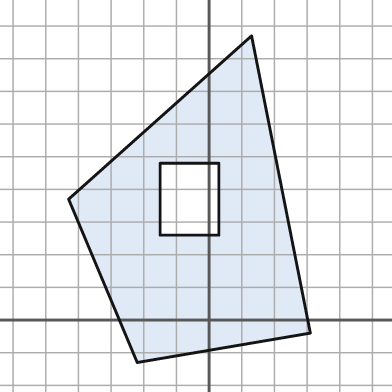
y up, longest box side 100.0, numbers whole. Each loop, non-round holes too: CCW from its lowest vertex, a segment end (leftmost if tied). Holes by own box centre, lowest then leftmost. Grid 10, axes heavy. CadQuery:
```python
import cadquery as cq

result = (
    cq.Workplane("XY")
    .moveTo(-22.0, -13.0)
    .lineTo(31.0, -4.0)
    .lineTo(13.0, 87.0)
    .lineTo(-43.0, 37.0)
    .close()
    .moveTo(-15.0, 26.0)
    .lineTo(3.0, 26.0)
    .lineTo(3.0, 48.0)
    .lineTo(-15.0, 48.0)
    .close()
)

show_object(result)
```